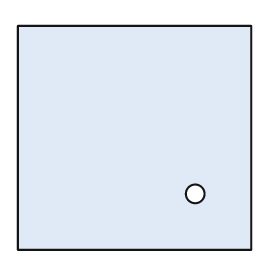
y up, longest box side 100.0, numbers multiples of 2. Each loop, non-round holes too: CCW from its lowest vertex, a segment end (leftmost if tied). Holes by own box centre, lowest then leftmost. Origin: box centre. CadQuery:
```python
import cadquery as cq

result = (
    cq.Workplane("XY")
    .moveTo(-50.0, -48.0)
    .lineTo(50.0, -48.0)
    .lineTo(50.0, 48.0)
    .lineTo(-50.0, 48.0)
    .close()
    .moveTo(26.0, -24.0)
    .circle(4.0)
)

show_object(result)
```